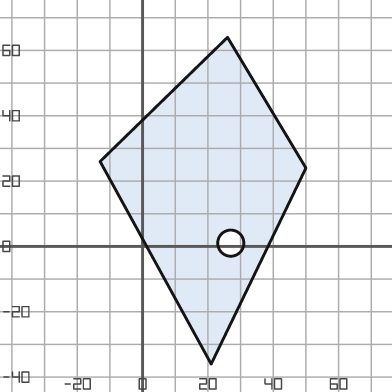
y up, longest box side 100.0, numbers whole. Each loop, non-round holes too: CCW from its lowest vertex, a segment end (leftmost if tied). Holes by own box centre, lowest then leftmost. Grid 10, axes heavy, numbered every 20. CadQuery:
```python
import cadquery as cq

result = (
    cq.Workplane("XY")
    .moveTo(21.0, -36.0)
    .lineTo(50.0, 24.0)
    .lineTo(26.0, 64.0)
    .lineTo(-13.0, 26.0)
    .close()
    .moveTo(27.0, 1.0)
    .circle(4.0)
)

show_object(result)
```